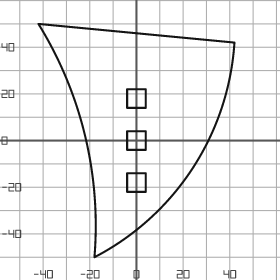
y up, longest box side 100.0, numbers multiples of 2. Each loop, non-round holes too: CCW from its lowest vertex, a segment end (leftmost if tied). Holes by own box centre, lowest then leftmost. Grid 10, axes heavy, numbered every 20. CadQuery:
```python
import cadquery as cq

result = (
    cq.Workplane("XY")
    .moveTo(-18.0, -50.0)
    .threePointArc((24.0, -12.0), (42.0, 42.0))
    .lineTo(-42.0, 50.0)
    .threePointArc((-22.0, 2.0), (-18.0, -50.0))
    .close()
    .moveTo(-4.0, -22.0)
    .lineTo(4.0, -22.0)
    .lineTo(4.0, -14.0)
    .lineTo(-4.0, -14.0)
    .close()
    .moveTo(-4.0, -4.0)
    .lineTo(4.0, -4.0)
    .lineTo(4.0, 4.0)
    .lineTo(-4.0, 4.0)
    .close()
    .moveTo(-4.0, 14.0)
    .lineTo(4.0, 14.0)
    .lineTo(4.0, 22.0)
    .lineTo(-4.0, 22.0)
    .close()
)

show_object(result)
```